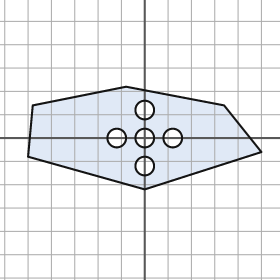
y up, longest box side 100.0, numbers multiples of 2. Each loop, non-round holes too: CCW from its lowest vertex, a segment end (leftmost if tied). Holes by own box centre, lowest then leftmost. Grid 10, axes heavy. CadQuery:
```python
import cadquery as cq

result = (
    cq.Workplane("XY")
    .moveTo(0.0, -22.0)
    .lineTo(50.0, -6.0)
    .lineTo(34.0, 14.0)
    .lineTo(-8.0, 22.0)
    .lineTo(-48.0, 14.0)
    .lineTo(-50.0, -8.0)
    .close()
    .moveTo(0.0, -12.0)
    .circle(4.0)
    .moveTo(-12.0, 0.0)
    .circle(4.0)
    .moveTo(0.0, 0.0)
    .circle(4.0)
    .moveTo(12.0, 0.0)
    .circle(4.0)
    .moveTo(0.0, 12.0)
    .circle(4.0)
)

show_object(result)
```